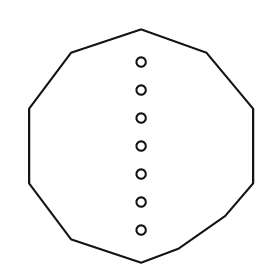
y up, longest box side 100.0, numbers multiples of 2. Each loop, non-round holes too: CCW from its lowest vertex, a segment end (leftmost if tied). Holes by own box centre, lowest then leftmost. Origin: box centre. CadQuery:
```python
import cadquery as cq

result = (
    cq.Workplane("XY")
    .moveTo(0.0, -50.0)
    .lineTo(16.0, -44.0)
    .lineTo(36.0, -30.0)
    .lineTo(48.0, -16.0)
    .lineTo(48.0, 16.0)
    .lineTo(28.0, 40.0)
    .lineTo(0.0, 50.0)
    .lineTo(-30.0, 40.0)
    .lineTo(-48.0, 16.0)
    .lineTo(-48.0, -16.0)
    .lineTo(-30.0, -40.0)
    .close()
    .moveTo(0.0, -36.0)
    .circle(2.0)
    .moveTo(0.0, -24.0)
    .circle(2.0)
    .moveTo(0.0, -12.0)
    .circle(2.0)
    .moveTo(0.0, 0.0)
    .circle(2.0)
    .moveTo(0.0, 12.0)
    .circle(2.0)
    .moveTo(0.0, 24.0)
    .circle(2.0)
    .moveTo(0.0, 36.0)
    .circle(2.0)
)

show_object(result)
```